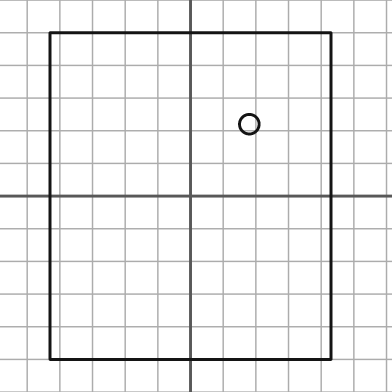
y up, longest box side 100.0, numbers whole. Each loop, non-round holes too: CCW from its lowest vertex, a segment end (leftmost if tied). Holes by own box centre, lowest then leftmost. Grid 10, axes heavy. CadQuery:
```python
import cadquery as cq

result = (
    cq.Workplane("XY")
    .moveTo(-43.0, -50.0)
    .lineTo(43.0, -50.0)
    .lineTo(43.0, 50.0)
    .lineTo(-43.0, 50.0)
    .close()
    .moveTo(18.0, 22.0)
    .circle(3.0)
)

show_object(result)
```